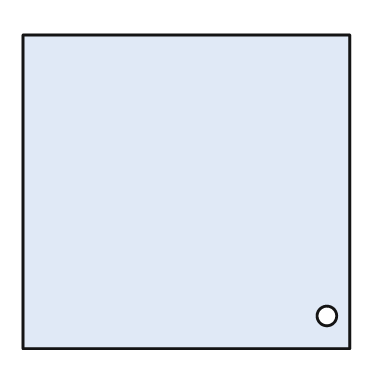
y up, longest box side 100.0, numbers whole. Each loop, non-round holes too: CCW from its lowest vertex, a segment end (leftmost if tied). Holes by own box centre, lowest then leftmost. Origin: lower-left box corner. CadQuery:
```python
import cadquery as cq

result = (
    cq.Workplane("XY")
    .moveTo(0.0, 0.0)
    .lineTo(100.0, 0.0)
    .lineTo(100.0, 96.0)
    .lineTo(0.0, 96.0)
    .close()
    .moveTo(93.0, 10.0)
    .circle(3.0)
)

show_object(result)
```